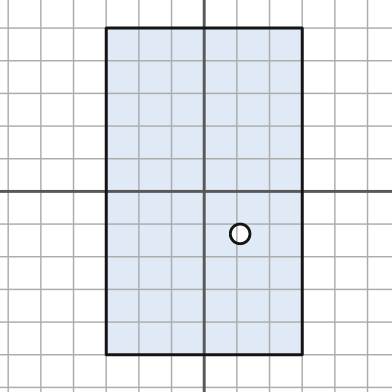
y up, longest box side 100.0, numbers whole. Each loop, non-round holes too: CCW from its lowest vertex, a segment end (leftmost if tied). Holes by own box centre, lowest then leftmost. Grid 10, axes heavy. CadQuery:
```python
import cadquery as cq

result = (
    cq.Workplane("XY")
    .moveTo(-30.0, -50.0)
    .lineTo(30.0, -50.0)
    .lineTo(30.0, 50.0)
    .lineTo(-30.0, 50.0)
    .close()
    .moveTo(11.0, -13.0)
    .circle(3.0)
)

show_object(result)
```